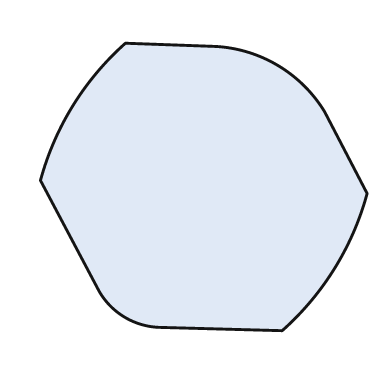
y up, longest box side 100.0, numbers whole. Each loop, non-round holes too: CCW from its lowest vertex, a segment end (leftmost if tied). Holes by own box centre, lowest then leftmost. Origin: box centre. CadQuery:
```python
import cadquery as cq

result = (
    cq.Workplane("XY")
    .moveTo(24.0, -44.0)
    .threePointArc((40.0, -25.0), (50.0, -2.0))
    .lineTo(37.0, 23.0)
    .threePointArc((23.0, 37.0), (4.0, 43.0))
    .lineTo(-24.0, 44.0)
    .threePointArc((-40.0, 25.0), (-50.0, 2.0))
    .lineTo(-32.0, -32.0)
    .threePointArc((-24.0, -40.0), (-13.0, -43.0))
    .close()
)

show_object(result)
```